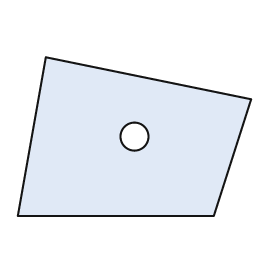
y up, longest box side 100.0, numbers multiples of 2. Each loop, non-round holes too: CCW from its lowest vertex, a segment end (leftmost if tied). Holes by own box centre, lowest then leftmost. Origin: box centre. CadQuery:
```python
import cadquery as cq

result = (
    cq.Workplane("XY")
    .moveTo(-50.0, -34.0)
    .lineTo(34.0, -34.0)
    .lineTo(50.0, 16.0)
    .lineTo(-38.0, 34.0)
    .close()
    .moveTo(0.0, 0.0)
    .circle(6.0)
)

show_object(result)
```